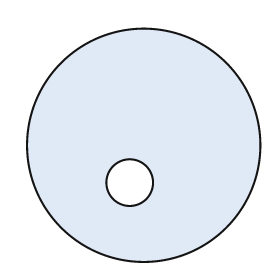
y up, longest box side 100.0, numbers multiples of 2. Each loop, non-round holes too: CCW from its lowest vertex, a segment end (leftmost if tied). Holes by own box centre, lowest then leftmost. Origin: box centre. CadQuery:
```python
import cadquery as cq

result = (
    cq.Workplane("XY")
    .moveTo(0.0, 0.0)
    .circle(50.0)
    .moveTo(-6.0, -16.0)
    .circle(10.0)
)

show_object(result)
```